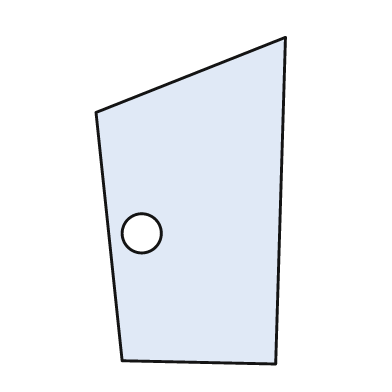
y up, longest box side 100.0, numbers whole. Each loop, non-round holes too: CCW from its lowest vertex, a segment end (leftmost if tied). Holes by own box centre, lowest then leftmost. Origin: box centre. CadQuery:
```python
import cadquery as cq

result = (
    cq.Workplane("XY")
    .moveTo(26.0, -50.0)
    .lineTo(29.0, 50.0)
    .lineTo(-29.0, 27.0)
    .lineTo(-21.0, -49.0)
    .close()
    .moveTo(-15.0, -10.0)
    .circle(6.0)
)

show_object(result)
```